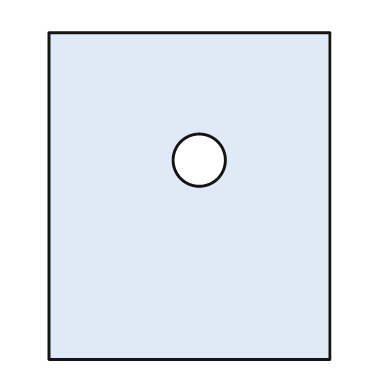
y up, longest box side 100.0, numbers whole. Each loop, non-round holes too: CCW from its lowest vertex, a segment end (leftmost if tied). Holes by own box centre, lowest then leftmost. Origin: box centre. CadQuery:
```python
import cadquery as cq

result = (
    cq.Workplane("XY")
    .moveTo(-43.0, -50.0)
    .lineTo(43.0, -50.0)
    .lineTo(43.0, 50.0)
    .lineTo(-43.0, 50.0)
    .close()
    .moveTo(3.0, 11.0)
    .circle(8.0)
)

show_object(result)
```